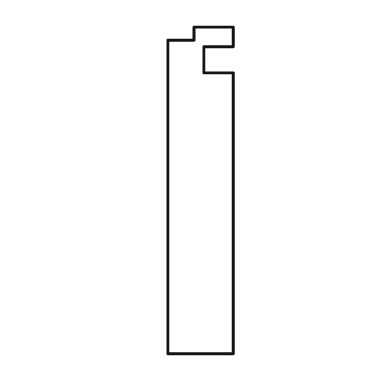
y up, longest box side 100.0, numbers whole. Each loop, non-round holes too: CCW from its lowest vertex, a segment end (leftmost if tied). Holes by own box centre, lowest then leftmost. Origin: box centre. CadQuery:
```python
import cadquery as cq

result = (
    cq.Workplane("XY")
    .moveTo(-10.0, -50.0)
    .lineTo(10.0, -50.0)
    .lineTo(10.0, 36.0)
    .lineTo(1.0, 36.0)
    .lineTo(1.0, 44.0)
    .lineTo(10.0, 44.0)
    .lineTo(10.0, 50.0)
    .lineTo(-2.0, 50.0)
    .lineTo(-2.0, 46.0)
    .lineTo(-10.0, 46.0)
    .close()
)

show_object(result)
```